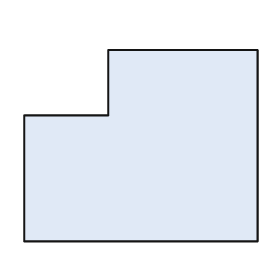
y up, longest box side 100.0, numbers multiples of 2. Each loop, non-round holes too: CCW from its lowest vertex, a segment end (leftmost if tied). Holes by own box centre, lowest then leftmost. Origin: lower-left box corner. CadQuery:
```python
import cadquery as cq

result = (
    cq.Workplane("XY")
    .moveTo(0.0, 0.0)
    .lineTo(100.0, 0.0)
    .lineTo(100.0, 82.0)
    .lineTo(36.0, 82.0)
    .lineTo(36.0, 54.0)
    .lineTo(0.0, 54.0)
    .close()
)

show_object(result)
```